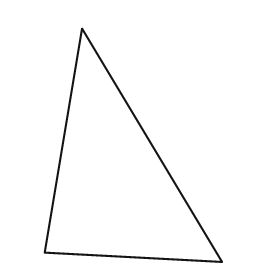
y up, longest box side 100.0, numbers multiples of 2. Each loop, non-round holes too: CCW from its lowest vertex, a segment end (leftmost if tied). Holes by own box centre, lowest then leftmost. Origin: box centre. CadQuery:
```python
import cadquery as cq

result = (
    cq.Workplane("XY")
    .moveTo(38.0, -50.0)
    .lineTo(-22.0, 50.0)
    .lineTo(-38.0, -46.0)
    .close()
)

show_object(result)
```